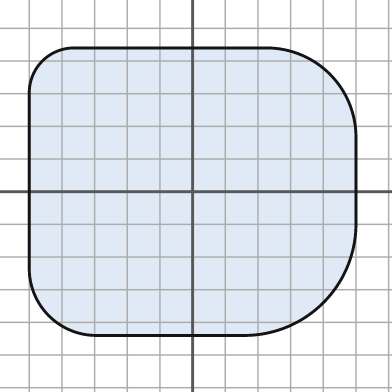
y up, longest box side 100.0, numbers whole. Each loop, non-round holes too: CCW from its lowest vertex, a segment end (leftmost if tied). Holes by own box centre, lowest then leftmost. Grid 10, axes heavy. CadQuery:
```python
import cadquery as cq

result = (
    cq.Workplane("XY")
    .moveTo(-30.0, -44.0)
    .lineTo(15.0, -44.0)
    .threePointArc((40.0, -34.0), (50.0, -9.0))
    .lineTo(50.0, 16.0)
    .threePointArc((42.0, 36.0), (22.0, 44.0))
    .lineTo(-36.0, 44.0)
    .threePointArc((-46.0, 40.0), (-50.0, 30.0))
    .lineTo(-50.0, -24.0)
    .threePointArc((-44.0, -38.0), (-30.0, -44.0))
    .close()
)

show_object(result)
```